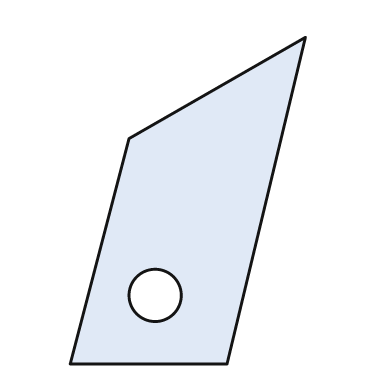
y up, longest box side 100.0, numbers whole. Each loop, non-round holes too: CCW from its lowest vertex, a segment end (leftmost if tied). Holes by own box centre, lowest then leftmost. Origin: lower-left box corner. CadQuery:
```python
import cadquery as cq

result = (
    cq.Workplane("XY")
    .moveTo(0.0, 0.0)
    .lineTo(48.0, 0.0)
    .lineTo(72.0, 100.0)
    .lineTo(18.0, 69.0)
    .close()
    .moveTo(26.0, 21.0)
    .circle(8.0)
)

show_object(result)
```